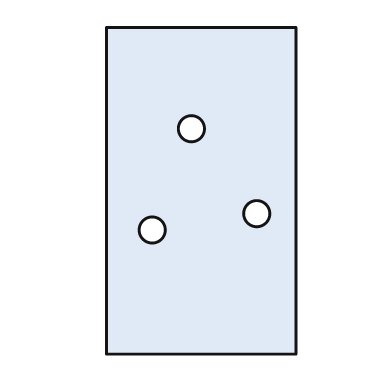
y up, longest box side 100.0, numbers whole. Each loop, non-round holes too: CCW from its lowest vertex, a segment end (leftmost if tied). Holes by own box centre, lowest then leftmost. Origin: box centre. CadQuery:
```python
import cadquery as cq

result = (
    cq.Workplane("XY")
    .moveTo(-29.0, -50.0)
    .lineTo(29.0, -50.0)
    .lineTo(29.0, 50.0)
    .lineTo(-29.0, 50.0)
    .close()
    .moveTo(-15.0, -12.0)
    .circle(4.0)
    .moveTo(17.0, -7.0)
    .circle(4.0)
    .moveTo(-3.0, 19.0)
    .circle(4.0)
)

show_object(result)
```